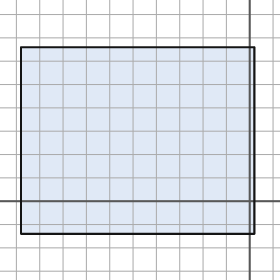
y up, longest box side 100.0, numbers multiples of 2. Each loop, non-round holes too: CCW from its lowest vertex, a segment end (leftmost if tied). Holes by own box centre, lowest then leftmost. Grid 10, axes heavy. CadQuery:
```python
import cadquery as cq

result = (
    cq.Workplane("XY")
    .moveTo(-98.0, -14.0)
    .lineTo(2.0, -14.0)
    .lineTo(2.0, 66.0)
    .lineTo(-98.0, 66.0)
    .close()
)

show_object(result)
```